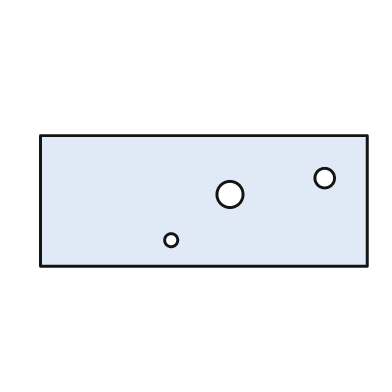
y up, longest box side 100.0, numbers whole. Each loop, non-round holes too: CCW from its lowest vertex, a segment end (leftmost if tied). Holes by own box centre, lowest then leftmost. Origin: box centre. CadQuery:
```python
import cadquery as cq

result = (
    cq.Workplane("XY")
    .moveTo(-50.0, -20.0)
    .lineTo(50.0, -20.0)
    .lineTo(50.0, 20.0)
    .lineTo(-50.0, 20.0)
    .close()
    .moveTo(-10.0, -12.0)
    .circle(2.0)
    .moveTo(8.0, 2.0)
    .circle(4.0)
    .moveTo(37.0, 7.0)
    .circle(3.0)
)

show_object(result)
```